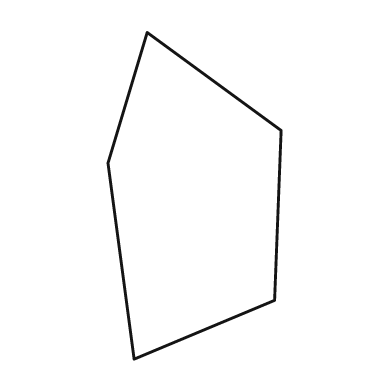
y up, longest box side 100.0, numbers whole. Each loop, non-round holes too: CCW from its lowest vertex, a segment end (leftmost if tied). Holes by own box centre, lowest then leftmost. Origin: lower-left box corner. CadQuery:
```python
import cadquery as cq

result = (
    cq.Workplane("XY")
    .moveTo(8.0, 0.0)
    .lineTo(51.0, 18.0)
    .lineTo(53.0, 70.0)
    .lineTo(12.0, 100.0)
    .lineTo(0.0, 60.0)
    .close()
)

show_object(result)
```